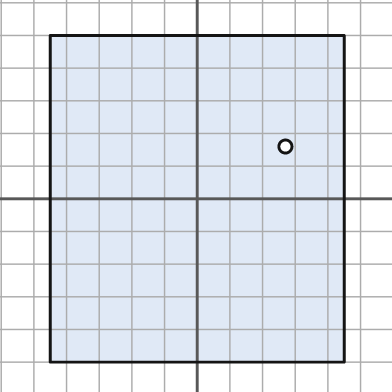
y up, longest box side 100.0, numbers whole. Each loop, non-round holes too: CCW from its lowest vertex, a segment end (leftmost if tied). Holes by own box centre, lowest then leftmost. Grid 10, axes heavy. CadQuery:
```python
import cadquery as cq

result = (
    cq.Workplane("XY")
    .moveTo(-45.0, -50.0)
    .lineTo(45.0, -50.0)
    .lineTo(45.0, 50.0)
    .lineTo(-45.0, 50.0)
    .close()
    .moveTo(27.0, 16.0)
    .circle(2.0)
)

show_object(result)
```